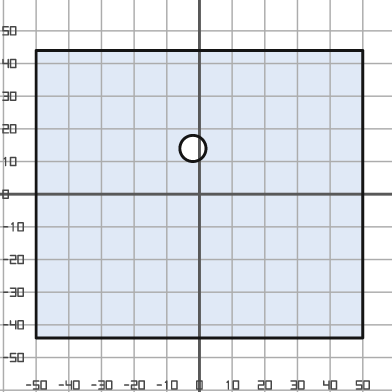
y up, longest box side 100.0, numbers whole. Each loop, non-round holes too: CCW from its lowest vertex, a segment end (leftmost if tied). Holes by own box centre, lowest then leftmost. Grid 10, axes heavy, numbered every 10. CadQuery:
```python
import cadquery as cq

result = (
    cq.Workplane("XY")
    .moveTo(-50.0, -44.0)
    .lineTo(50.0, -44.0)
    .lineTo(50.0, 44.0)
    .lineTo(-50.0, 44.0)
    .close()
    .moveTo(-2.0, 14.0)
    .circle(4.0)
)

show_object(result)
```